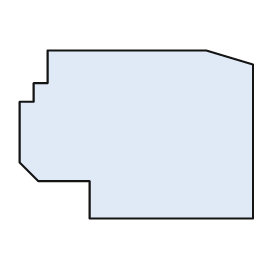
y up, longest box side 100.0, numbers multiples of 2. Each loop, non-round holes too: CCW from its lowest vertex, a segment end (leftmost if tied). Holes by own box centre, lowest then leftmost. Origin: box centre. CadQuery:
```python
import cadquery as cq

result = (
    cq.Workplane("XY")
    .moveTo(-20.0, -36.0)
    .lineTo(50.0, -36.0)
    .lineTo(50.0, 30.0)
    .lineTo(30.0, 36.0)
    .lineTo(-38.0, 36.0)
    .lineTo(-38.0, 22.0)
    .lineTo(-44.0, 22.0)
    .lineTo(-44.0, 14.0)
    .lineTo(-50.0, 14.0)
    .lineTo(-50.0, -12.0)
    .lineTo(-42.0, -20.0)
    .lineTo(-20.0, -20.0)
    .close()
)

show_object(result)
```